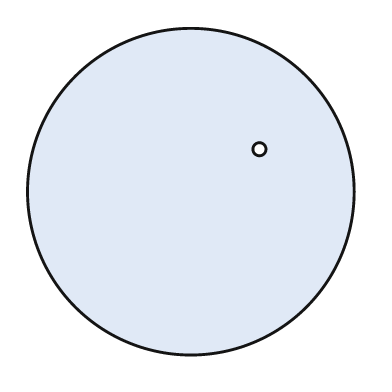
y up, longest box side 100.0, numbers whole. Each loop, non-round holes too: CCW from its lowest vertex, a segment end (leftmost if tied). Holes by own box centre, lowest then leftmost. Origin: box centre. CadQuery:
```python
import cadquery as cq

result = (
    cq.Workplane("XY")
    .moveTo(0.0, 0.0)
    .circle(50.0)
    .moveTo(21.0, 13.0)
    .circle(2.0)
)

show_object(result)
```